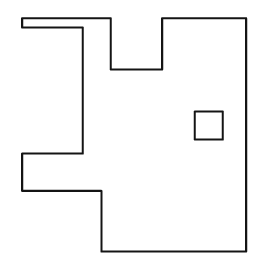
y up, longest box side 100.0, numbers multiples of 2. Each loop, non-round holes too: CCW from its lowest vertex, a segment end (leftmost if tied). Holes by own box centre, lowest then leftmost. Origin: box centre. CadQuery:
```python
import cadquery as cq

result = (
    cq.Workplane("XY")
    .moveTo(-14.0, -50.0)
    .lineTo(48.0, -50.0)
    .lineTo(48.0, 50.0)
    .lineTo(12.0, 50.0)
    .lineTo(12.0, 28.0)
    .lineTo(-10.0, 28.0)
    .lineTo(-10.0, 50.0)
    .lineTo(-48.0, 50.0)
    .lineTo(-48.0, 46.0)
    .lineTo(-22.0, 46.0)
    .lineTo(-22.0, -8.0)
    .lineTo(-48.0, -8.0)
    .lineTo(-48.0, -24.0)
    .lineTo(-14.0, -24.0)
    .close()
    .moveTo(26.0, -2.0)
    .lineTo(38.0, -2.0)
    .lineTo(38.0, 10.0)
    .lineTo(26.0, 10.0)
    .close()
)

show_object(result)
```